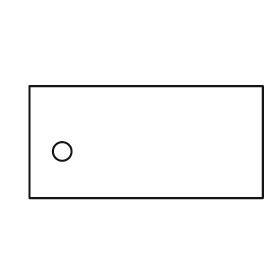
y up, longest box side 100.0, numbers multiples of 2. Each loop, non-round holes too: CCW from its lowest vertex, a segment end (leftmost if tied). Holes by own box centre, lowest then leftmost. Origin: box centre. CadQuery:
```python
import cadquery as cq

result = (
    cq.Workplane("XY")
    .moveTo(-50.0, -24.0)
    .lineTo(50.0, -24.0)
    .lineTo(50.0, 24.0)
    .lineTo(-50.0, 24.0)
    .close()
    .moveTo(-36.0, -4.0)
    .circle(4.0)
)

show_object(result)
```